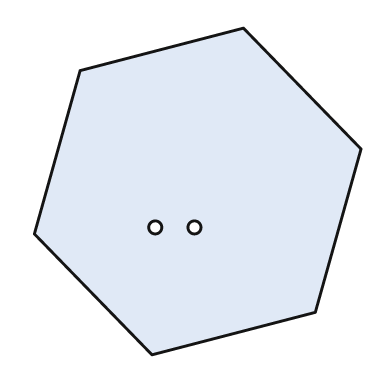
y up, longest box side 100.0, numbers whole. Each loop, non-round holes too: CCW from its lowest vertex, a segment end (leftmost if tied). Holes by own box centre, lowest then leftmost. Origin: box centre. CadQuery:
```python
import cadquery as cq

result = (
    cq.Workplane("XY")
    .moveTo(-14.0, -50.0)
    .lineTo(36.0, -37.0)
    .lineTo(50.0, 13.0)
    .lineTo(14.0, 50.0)
    .lineTo(-36.0, 37.0)
    .lineTo(-50.0, -13.0)
    .close()
    .moveTo(-13.0, -11.0)
    .circle(2.0)
    .moveTo(-1.0, -11.0)
    .circle(2.0)
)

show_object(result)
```